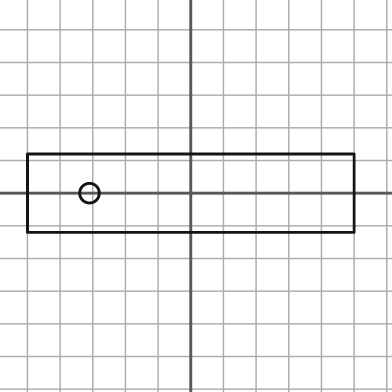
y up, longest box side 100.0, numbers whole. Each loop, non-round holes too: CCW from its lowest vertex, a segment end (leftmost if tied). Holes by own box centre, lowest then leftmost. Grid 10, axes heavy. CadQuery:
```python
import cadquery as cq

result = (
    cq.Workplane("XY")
    .moveTo(-50.0, -12.0)
    .lineTo(50.0, -12.0)
    .lineTo(50.0, 12.0)
    .lineTo(-50.0, 12.0)
    .close()
    .moveTo(-31.0, 0.0)
    .circle(3.0)
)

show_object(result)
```